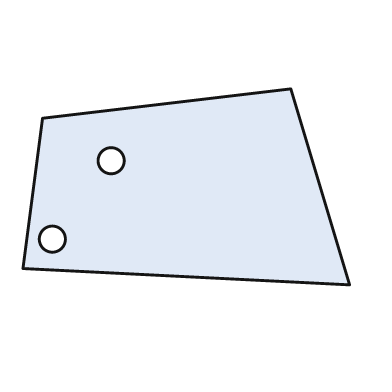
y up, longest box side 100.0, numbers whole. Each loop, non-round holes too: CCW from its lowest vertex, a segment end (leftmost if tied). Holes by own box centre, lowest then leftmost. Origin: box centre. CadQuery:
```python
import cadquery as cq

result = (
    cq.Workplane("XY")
    .moveTo(50.0, -30.0)
    .lineTo(32.0, 30.0)
    .lineTo(-44.0, 21.0)
    .lineTo(-50.0, -25.0)
    .close()
    .moveTo(-41.0, -16.0)
    .circle(4.0)
    .moveTo(-23.0, 8.0)
    .circle(4.0)
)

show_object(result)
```